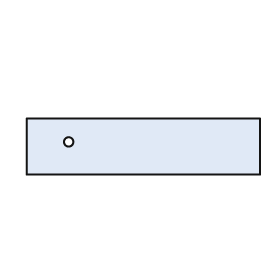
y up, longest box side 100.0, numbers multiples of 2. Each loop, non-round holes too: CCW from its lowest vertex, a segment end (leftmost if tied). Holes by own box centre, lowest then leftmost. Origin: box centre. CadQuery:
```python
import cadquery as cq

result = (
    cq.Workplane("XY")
    .moveTo(-50.0, -12.0)
    .lineTo(50.0, -12.0)
    .lineTo(50.0, 12.0)
    .lineTo(-50.0, 12.0)
    .close()
    .moveTo(-32.0, 2.0)
    .circle(2.0)
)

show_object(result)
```